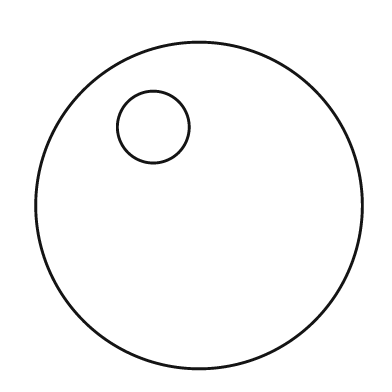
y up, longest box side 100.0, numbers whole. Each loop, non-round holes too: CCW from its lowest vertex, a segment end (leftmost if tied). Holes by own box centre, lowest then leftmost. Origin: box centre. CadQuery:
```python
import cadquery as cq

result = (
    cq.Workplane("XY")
    .moveTo(0.0, 0.0)
    .circle(50.0)
    .moveTo(-14.0, 24.0)
    .circle(11.0)
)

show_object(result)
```